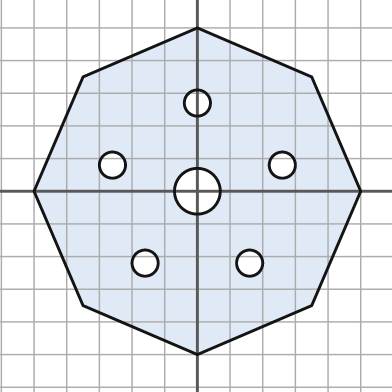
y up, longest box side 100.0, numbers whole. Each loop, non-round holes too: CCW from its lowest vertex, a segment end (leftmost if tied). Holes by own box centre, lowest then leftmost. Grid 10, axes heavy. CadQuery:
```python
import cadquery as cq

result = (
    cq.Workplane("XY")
    .moveTo(0.0, -50.0)
    .lineTo(35.0, -35.0)
    .lineTo(50.0, 0.0)
    .lineTo(35.0, 35.0)
    .lineTo(0.0, 50.0)
    .lineTo(-35.0, 35.0)
    .lineTo(-50.0, 0.0)
    .lineTo(-35.0, -35.0)
    .close()
    .moveTo(-16.0, -22.0)
    .circle(4.0)
    .moveTo(16.0, -22.0)
    .circle(4.0)
    .moveTo(0.0, 0.0)
    .circle(7.0)
    .moveTo(-26.0, 8.0)
    .circle(4.0)
    .moveTo(26.0, 8.0)
    .circle(4.0)
    .moveTo(0.0, 27.0)
    .circle(4.0)
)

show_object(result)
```